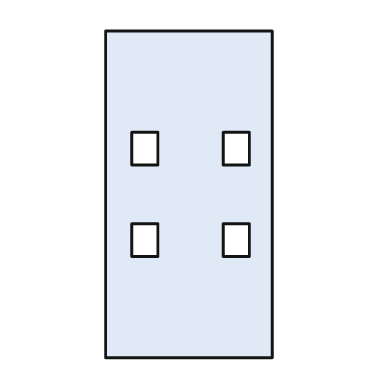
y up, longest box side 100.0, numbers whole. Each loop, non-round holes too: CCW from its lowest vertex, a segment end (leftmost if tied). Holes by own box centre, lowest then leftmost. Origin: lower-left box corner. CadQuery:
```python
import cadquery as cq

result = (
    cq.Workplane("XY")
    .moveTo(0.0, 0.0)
    .lineTo(51.0, 0.0)
    .lineTo(51.0, 100.0)
    .lineTo(0.0, 100.0)
    .close()
    .moveTo(8.0, 31.0)
    .lineTo(16.0, 31.0)
    .lineTo(16.0, 41.0)
    .lineTo(8.0, 41.0)
    .close()
    .moveTo(36.0, 31.0)
    .lineTo(44.0, 31.0)
    .lineTo(44.0, 41.0)
    .lineTo(36.0, 41.0)
    .close()
    .moveTo(8.0, 59.0)
    .lineTo(16.0, 59.0)
    .lineTo(16.0, 69.0)
    .lineTo(8.0, 69.0)
    .close()
    .moveTo(36.0, 59.0)
    .lineTo(44.0, 59.0)
    .lineTo(44.0, 69.0)
    .lineTo(36.0, 69.0)
    .close()
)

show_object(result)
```